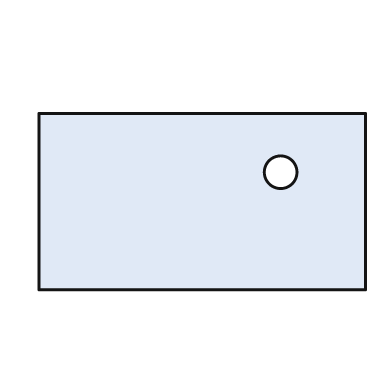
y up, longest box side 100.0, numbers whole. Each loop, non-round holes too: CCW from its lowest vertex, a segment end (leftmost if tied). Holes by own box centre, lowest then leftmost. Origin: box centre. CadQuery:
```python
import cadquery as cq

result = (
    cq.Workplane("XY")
    .moveTo(-50.0, -27.0)
    .lineTo(50.0, -27.0)
    .lineTo(50.0, 27.0)
    .lineTo(-50.0, 27.0)
    .close()
    .moveTo(24.0, 9.0)
    .circle(5.0)
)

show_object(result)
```